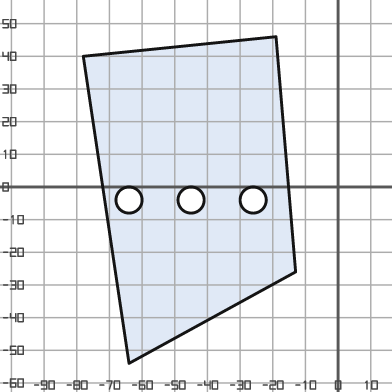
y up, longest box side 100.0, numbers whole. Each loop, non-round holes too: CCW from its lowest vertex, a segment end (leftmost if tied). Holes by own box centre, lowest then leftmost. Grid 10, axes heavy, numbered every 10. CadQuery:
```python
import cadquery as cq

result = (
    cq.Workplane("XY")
    .moveTo(-64.0, -54.0)
    .lineTo(-13.0, -26.0)
    .lineTo(-19.0, 46.0)
    .lineTo(-78.0, 40.0)
    .close()
    .moveTo(-64.0, -4.0)
    .circle(4.0)
    .moveTo(-45.0, -4.0)
    .circle(4.0)
    .moveTo(-26.0, -4.0)
    .circle(4.0)
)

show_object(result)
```